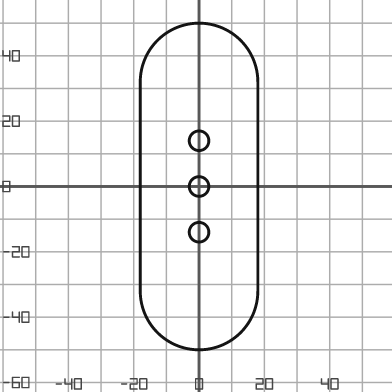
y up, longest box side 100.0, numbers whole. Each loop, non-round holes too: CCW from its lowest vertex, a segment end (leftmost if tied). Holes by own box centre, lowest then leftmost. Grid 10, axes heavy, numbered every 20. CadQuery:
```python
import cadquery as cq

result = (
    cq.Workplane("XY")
    .moveTo(-18.0, -32.0)
    .threePointArc((0.0, -50.0), (18.0, -32.0))
    .lineTo(18.0, 32.0)
    .threePointArc((0.0, 50.0), (-18.0, 32.0))
    .close()
    .moveTo(0.0, -14.0)
    .circle(3.0)
    .moveTo(0.0, 0.0)
    .circle(3.0)
    .moveTo(0.0, 14.0)
    .circle(3.0)
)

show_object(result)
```